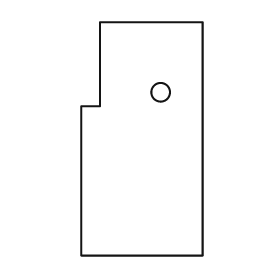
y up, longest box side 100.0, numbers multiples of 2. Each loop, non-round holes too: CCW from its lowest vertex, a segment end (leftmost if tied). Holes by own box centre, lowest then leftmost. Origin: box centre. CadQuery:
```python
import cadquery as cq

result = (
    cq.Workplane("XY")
    .moveTo(-26.0, -50.0)
    .lineTo(26.0, -50.0)
    .lineTo(26.0, 50.0)
    .lineTo(-18.0, 50.0)
    .lineTo(-18.0, 14.0)
    .lineTo(-26.0, 14.0)
    .close()
    .moveTo(8.0, 20.0)
    .circle(4.0)
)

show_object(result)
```